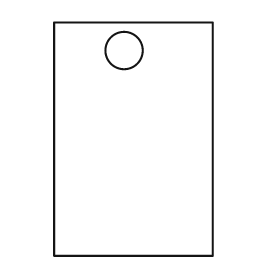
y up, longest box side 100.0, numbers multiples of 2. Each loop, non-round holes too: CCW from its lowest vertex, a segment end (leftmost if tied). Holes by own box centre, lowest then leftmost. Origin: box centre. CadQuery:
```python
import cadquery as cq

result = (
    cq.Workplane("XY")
    .moveTo(-34.0, -50.0)
    .lineTo(34.0, -50.0)
    .lineTo(34.0, 50.0)
    .lineTo(-34.0, 50.0)
    .close()
    .moveTo(-4.0, 38.0)
    .circle(8.0)
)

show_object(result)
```